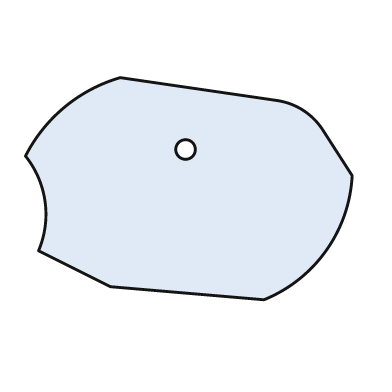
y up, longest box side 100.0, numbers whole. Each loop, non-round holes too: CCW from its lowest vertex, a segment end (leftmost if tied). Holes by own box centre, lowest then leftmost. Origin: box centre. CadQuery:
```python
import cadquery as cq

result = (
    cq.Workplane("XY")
    .moveTo(23.0, -34.0)
    .threePointArc((42.0, -19.0), (50.0, 4.0))
    .lineTo(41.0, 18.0)
    .threePointArc((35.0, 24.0), (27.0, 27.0))
    .lineTo(-21.0, 34.0)
    .threePointArc((-38.0, 25.0), (-50.0, 10.0))
    .threePointArc((-44.0, -4.0), (-46.0, -19.0))
    .lineTo(-24.0, -30.0)
    .close()
    .moveTo(-1.0, 12.0)
    .circle(3.0)
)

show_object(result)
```